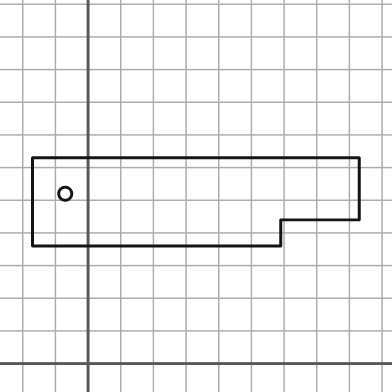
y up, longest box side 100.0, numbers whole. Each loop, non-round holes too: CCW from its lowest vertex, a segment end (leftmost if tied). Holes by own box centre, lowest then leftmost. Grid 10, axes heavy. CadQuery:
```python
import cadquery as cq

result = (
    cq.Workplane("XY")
    .moveTo(-17.0, 36.0)
    .lineTo(59.0, 36.0)
    .lineTo(59.0, 44.0)
    .lineTo(83.0, 44.0)
    .lineTo(83.0, 63.0)
    .lineTo(-17.0, 63.0)
    .close()
    .moveTo(-7.0, 52.0)
    .circle(2.0)
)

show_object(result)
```